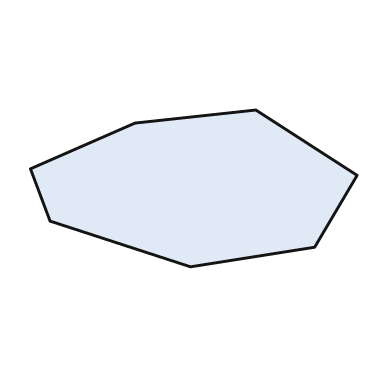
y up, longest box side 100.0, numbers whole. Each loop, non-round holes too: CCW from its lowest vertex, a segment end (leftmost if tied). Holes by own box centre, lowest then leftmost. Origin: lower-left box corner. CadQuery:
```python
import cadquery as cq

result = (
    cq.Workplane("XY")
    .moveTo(49.0, 0.0)
    .lineTo(87.0, 6.0)
    .lineTo(100.0, 28.0)
    .lineTo(69.0, 48.0)
    .lineTo(32.0, 44.0)
    .lineTo(0.0, 30.0)
    .lineTo(6.0, 14.0)
    .close()
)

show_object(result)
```